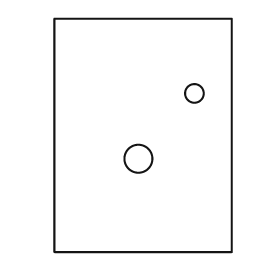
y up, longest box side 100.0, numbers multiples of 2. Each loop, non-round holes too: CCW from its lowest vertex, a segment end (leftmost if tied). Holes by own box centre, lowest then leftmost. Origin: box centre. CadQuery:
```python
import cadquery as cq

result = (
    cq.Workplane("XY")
    .moveTo(-38.0, -50.0)
    .lineTo(38.0, -50.0)
    .lineTo(38.0, 50.0)
    .lineTo(-38.0, 50.0)
    .close()
    .moveTo(-2.0, -10.0)
    .circle(6.0)
    .moveTo(22.0, 18.0)
    .circle(4.0)
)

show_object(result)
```